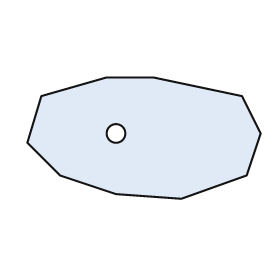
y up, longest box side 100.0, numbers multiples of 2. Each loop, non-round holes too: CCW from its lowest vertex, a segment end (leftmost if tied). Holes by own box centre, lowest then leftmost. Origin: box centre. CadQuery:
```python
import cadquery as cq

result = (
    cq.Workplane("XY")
    .moveTo(16.0, -26.0)
    .lineTo(44.0, -16.0)
    .lineTo(50.0, 2.0)
    .lineTo(42.0, 18.0)
    .lineTo(4.0, 26.0)
    .lineTo(-16.0, 26.0)
    .lineTo(-44.0, 18.0)
    .lineTo(-50.0, -2.0)
    .lineTo(-36.0, -16.0)
    .lineTo(-12.0, -24.0)
    .close()
    .moveTo(-12.0, 2.0)
    .circle(4.0)
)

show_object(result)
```